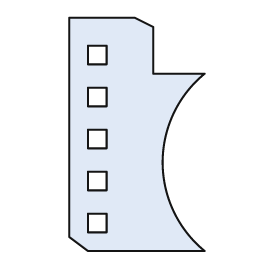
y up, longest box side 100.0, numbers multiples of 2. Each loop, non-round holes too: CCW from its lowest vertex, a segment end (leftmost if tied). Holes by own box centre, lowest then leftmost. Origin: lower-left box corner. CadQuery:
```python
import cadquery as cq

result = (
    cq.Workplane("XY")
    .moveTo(8.0, 0.0)
    .lineTo(58.0, 0.0)
    .threePointArc((40.0, 38.0), (58.0, 76.0))
    .lineTo(36.0, 76.0)
    .lineTo(36.0, 96.0)
    .lineTo(28.0, 100.0)
    .lineTo(0.0, 100.0)
    .lineTo(0.0, 6.0)
    .close()
    .moveTo(8.0, 8.0)
    .lineTo(16.0, 8.0)
    .lineTo(16.0, 16.0)
    .lineTo(8.0, 16.0)
    .close()
    .moveTo(8.0, 26.0)
    .lineTo(16.0, 26.0)
    .lineTo(16.0, 34.0)
    .lineTo(8.0, 34.0)
    .close()
    .moveTo(8.0, 44.0)
    .lineTo(16.0, 44.0)
    .lineTo(16.0, 52.0)
    .lineTo(8.0, 52.0)
    .close()
    .moveTo(8.0, 62.0)
    .lineTo(16.0, 62.0)
    .lineTo(16.0, 70.0)
    .lineTo(8.0, 70.0)
    .close()
    .moveTo(8.0, 80.0)
    .lineTo(16.0, 80.0)
    .lineTo(16.0, 88.0)
    .lineTo(8.0, 88.0)
    .close()
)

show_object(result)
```